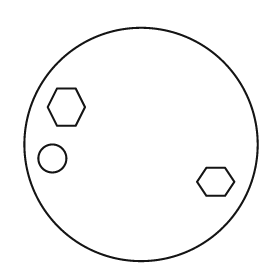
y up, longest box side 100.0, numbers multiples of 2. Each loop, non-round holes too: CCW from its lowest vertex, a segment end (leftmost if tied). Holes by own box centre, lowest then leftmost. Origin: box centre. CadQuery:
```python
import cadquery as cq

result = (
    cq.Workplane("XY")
    .moveTo(0.0, 0.0)
    .circle(50.0)
    .moveTo(28.0, -22.0)
    .lineTo(36.0, -22.0)
    .lineTo(40.0, -16.0)
    .lineTo(36.0, -10.0)
    .lineTo(28.0, -10.0)
    .lineTo(24.0, -16.0)
    .close()
    .moveTo(-38.0, -6.0)
    .circle(6.0)
    .moveTo(-36.0, 8.0)
    .lineTo(-28.0, 8.0)
    .lineTo(-24.0, 16.0)
    .lineTo(-28.0, 24.0)
    .lineTo(-36.0, 24.0)
    .lineTo(-40.0, 16.0)
    .close()
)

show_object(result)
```